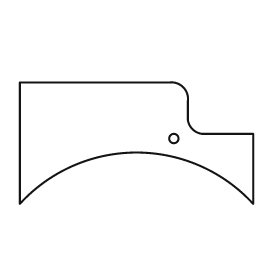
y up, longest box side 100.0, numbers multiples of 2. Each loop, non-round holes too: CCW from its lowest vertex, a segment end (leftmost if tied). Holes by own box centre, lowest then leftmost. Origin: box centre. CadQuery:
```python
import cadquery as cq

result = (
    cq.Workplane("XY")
    .moveTo(-50.0, -26.0)
    .threePointArc((0.0, -4.0), (50.0, -26.0))
    .lineTo(50.0, 4.0)
    .lineTo(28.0, 4.0)
    .threePointArc((24.0, 6.0), (22.0, 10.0))
    .lineTo(22.0, 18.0)
    .threePointArc((20.0, 24.0), (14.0, 26.0))
    .lineTo(-50.0, 26.0)
    .close()
    .moveTo(16.0, 2.0)
    .circle(2.0)
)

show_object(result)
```